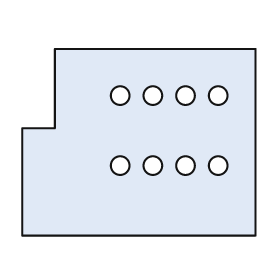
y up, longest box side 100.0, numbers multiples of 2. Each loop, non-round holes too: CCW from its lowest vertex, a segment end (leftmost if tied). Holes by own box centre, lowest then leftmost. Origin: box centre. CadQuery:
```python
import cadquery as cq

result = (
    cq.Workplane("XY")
    .moveTo(-50.0, -40.0)
    .lineTo(50.0, -40.0)
    .lineTo(50.0, 40.0)
    .lineTo(-36.0, 40.0)
    .lineTo(-36.0, 6.0)
    .lineTo(-50.0, 6.0)
    .close()
    .moveTo(-8.0, -10.0)
    .circle(4.0)
    .moveTo(6.0, -10.0)
    .circle(4.0)
    .moveTo(20.0, -10.0)
    .circle(4.0)
    .moveTo(34.0, -10.0)
    .circle(4.0)
    .moveTo(-8.0, 20.0)
    .circle(4.0)
    .moveTo(6.0, 20.0)
    .circle(4.0)
    .moveTo(20.0, 20.0)
    .circle(4.0)
    .moveTo(34.0, 20.0)
    .circle(4.0)
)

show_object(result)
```